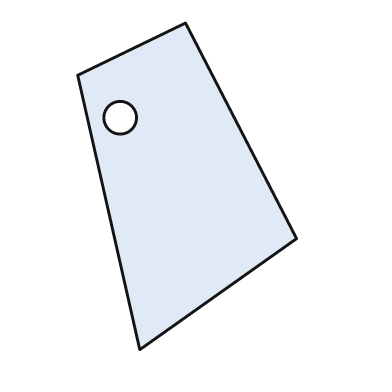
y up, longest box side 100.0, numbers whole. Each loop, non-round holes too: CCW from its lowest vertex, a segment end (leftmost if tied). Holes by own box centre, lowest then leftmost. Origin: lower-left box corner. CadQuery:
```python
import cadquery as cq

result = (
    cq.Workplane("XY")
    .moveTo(19.0, 0.0)
    .lineTo(67.0, 34.0)
    .lineTo(33.0, 100.0)
    .lineTo(0.0, 84.0)
    .close()
    .moveTo(13.0, 71.0)
    .circle(5.0)
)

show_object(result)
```